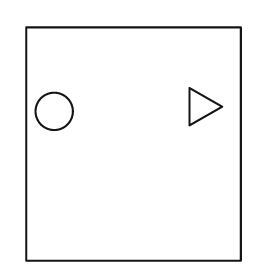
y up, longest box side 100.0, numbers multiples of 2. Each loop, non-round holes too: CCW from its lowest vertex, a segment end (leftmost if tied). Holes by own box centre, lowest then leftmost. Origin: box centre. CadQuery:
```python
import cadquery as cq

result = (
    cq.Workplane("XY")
    .moveTo(-46.0, -50.0)
    .lineTo(46.0, -50.0)
    .lineTo(46.0, 50.0)
    .lineTo(-46.0, 50.0)
    .close()
    .moveTo(-34.0, 14.0)
    .circle(8.0)
    .moveTo(24.0, 8.0)
    .lineTo(38.0, 16.0)
    .lineTo(24.0, 24.0)
    .close()
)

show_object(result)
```